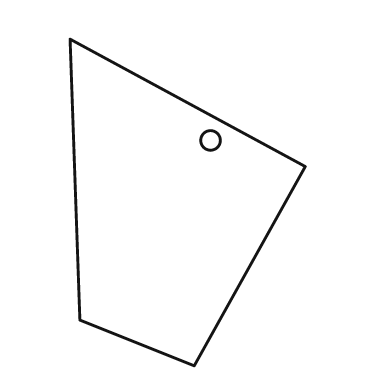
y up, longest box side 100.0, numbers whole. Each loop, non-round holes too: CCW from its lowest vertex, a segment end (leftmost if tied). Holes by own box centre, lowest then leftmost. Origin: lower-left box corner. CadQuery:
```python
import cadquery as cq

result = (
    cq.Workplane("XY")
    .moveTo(38.0, 0.0)
    .lineTo(72.0, 61.0)
    .lineTo(0.0, 100.0)
    .lineTo(3.0, 14.0)
    .close()
    .moveTo(43.0, 69.0)
    .circle(3.0)
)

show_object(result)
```